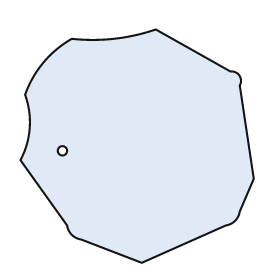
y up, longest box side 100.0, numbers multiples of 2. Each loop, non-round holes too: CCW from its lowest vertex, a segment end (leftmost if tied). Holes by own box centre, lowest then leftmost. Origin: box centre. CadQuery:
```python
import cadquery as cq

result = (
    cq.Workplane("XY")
    .moveTo(2.0, -50.0)
    .lineTo(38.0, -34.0)
    .threePointArc((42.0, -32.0), (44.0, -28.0))
    .lineTo(50.0, -14.0)
    .lineTo(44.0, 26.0)
    .threePointArc((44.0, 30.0), (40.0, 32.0))
    .lineTo(8.0, 50.0)
    .threePointArc((-10.0, 46.0), (-28.0, 46.0))
    .threePointArc((-40.0, 36.0), (-48.0, 22.0))
    .threePointArc((-46.0, 8.0), (-50.0, -6.0))
    .lineTo(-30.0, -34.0)
    .threePointArc((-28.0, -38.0), (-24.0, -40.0))
    .close()
    .moveTo(-32.0, -2.0)
    .circle(2.0)
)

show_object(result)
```